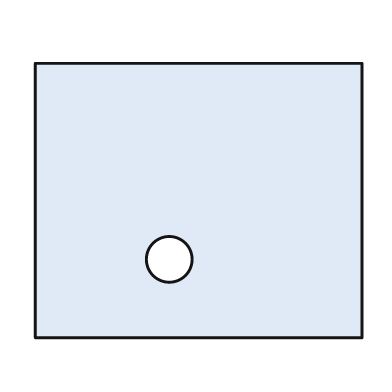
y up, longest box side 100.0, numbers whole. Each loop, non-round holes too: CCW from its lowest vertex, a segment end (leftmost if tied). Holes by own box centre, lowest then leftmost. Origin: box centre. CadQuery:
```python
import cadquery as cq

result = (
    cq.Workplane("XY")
    .moveTo(-50.0, -42.0)
    .lineTo(50.0, -42.0)
    .lineTo(50.0, 42.0)
    .lineTo(-50.0, 42.0)
    .close()
    .moveTo(-9.0, -18.0)
    .circle(7.0)
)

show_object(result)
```